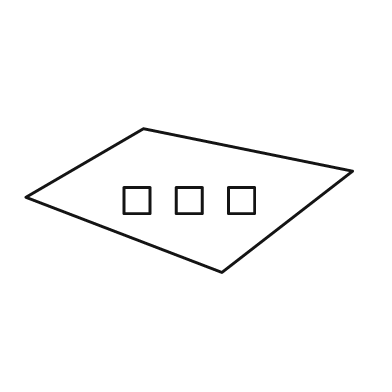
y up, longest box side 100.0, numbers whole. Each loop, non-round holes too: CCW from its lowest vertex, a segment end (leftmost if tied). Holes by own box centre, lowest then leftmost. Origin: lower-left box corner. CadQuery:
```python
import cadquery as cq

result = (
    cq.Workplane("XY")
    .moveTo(60.0, 0.0)
    .lineTo(100.0, 31.0)
    .lineTo(36.0, 44.0)
    .lineTo(0.0, 23.0)
    .close()
    .moveTo(30.0, 18.0)
    .lineTo(38.0, 18.0)
    .lineTo(38.0, 26.0)
    .lineTo(30.0, 26.0)
    .close()
    .moveTo(46.0, 18.0)
    .lineTo(54.0, 18.0)
    .lineTo(54.0, 26.0)
    .lineTo(46.0, 26.0)
    .close()
    .moveTo(62.0, 18.0)
    .lineTo(70.0, 18.0)
    .lineTo(70.0, 26.0)
    .lineTo(62.0, 26.0)
    .close()
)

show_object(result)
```